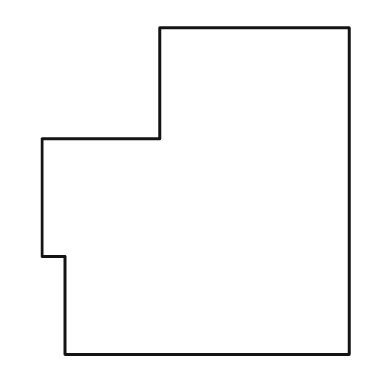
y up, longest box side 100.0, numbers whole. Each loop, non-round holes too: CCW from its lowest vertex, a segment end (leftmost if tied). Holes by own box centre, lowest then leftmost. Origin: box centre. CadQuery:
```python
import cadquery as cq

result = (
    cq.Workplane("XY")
    .moveTo(-40.0, -50.0)
    .lineTo(47.0, -50.0)
    .lineTo(47.0, 50.0)
    .lineTo(-11.0, 50.0)
    .lineTo(-11.0, 16.0)
    .lineTo(-47.0, 16.0)
    .lineTo(-47.0, -20.0)
    .lineTo(-40.0, -20.0)
    .close()
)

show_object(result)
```